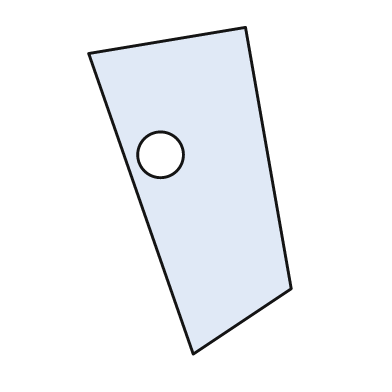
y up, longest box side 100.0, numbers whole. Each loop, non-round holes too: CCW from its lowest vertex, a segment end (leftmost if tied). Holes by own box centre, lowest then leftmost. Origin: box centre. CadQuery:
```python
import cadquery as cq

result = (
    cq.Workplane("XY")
    .moveTo(1.0, -50.0)
    .lineTo(31.0, -30.0)
    .lineTo(17.0, 50.0)
    .lineTo(-31.0, 42.0)
    .close()
    .moveTo(-9.0, 11.0)
    .circle(7.0)
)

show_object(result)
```